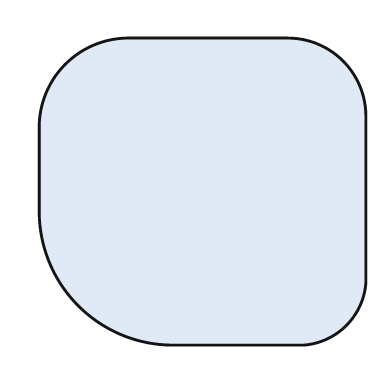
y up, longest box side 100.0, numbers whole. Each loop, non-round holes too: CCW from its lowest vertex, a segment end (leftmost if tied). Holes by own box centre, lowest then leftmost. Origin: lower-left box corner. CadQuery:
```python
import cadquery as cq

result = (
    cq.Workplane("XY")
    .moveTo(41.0, 0.0)
    .lineTo(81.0, 0.0)
    .threePointArc((94.0, 6.0), (100.0, 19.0))
    .lineTo(100.0, 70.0)
    .threePointArc((93.0, 87.0), (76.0, 94.0))
    .lineTo(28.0, 94.0)
    .threePointArc((8.0, 86.0), (0.0, 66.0))
    .lineTo(0.0, 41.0)
    .threePointArc((12.0, 12.0), (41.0, 0.0))
    .close()
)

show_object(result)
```